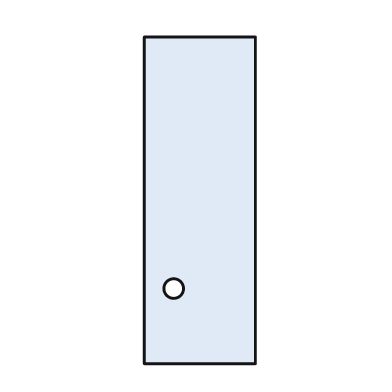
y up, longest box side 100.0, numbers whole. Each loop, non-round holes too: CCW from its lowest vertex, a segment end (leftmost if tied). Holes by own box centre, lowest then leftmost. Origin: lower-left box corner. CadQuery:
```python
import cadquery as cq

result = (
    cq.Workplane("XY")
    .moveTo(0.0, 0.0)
    .lineTo(34.0, 0.0)
    .lineTo(34.0, 100.0)
    .lineTo(0.0, 100.0)
    .close()
    .moveTo(9.0, 23.0)
    .circle(3.0)
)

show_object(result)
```